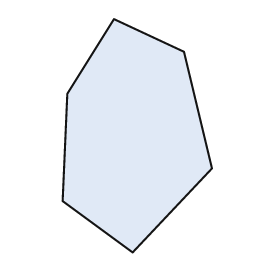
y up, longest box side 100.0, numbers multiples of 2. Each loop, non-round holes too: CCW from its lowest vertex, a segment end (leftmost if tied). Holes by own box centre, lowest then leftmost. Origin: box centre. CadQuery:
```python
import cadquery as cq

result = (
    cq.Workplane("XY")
    .moveTo(-2.0, -50.0)
    .lineTo(32.0, -14.0)
    .lineTo(20.0, 36.0)
    .lineTo(-10.0, 50.0)
    .lineTo(-30.0, 18.0)
    .lineTo(-32.0, -28.0)
    .close()
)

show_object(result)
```